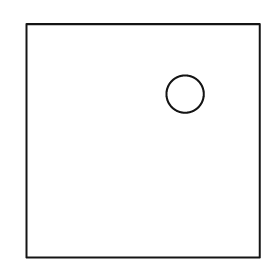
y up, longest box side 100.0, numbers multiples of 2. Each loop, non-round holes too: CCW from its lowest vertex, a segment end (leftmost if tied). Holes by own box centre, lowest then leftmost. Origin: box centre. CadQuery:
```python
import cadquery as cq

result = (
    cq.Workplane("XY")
    .moveTo(-50.0, -50.0)
    .lineTo(50.0, -50.0)
    .lineTo(50.0, 50.0)
    .lineTo(-50.0, 50.0)
    .close()
    .moveTo(18.0, 20.0)
    .circle(8.0)
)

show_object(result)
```